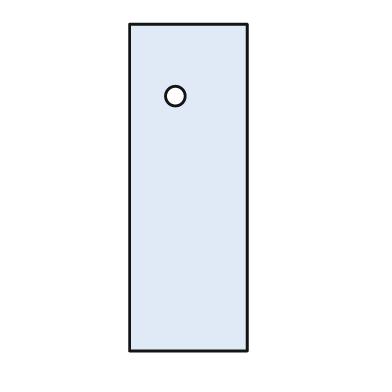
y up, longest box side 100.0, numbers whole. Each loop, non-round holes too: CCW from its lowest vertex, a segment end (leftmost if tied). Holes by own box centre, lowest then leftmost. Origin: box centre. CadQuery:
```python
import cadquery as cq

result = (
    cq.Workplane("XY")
    .moveTo(-18.0, -50.0)
    .lineTo(18.0, -50.0)
    .lineTo(18.0, 50.0)
    .lineTo(-18.0, 50.0)
    .close()
    .moveTo(-4.0, 28.0)
    .circle(3.0)
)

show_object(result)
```